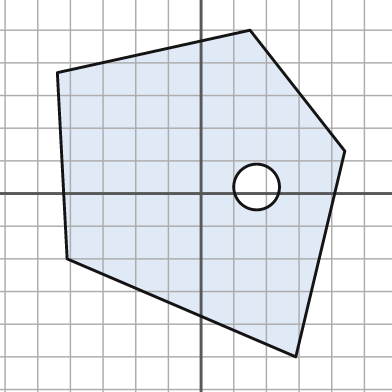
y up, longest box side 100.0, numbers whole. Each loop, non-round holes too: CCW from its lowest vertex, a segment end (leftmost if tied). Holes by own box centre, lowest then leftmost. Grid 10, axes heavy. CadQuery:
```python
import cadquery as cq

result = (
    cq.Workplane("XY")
    .moveTo(29.0, -50.0)
    .lineTo(44.0, 13.0)
    .lineTo(15.0, 50.0)
    .lineTo(-44.0, 37.0)
    .lineTo(-41.0, -20.0)
    .close()
    .moveTo(17.0, 2.0)
    .circle(7.0)
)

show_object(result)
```